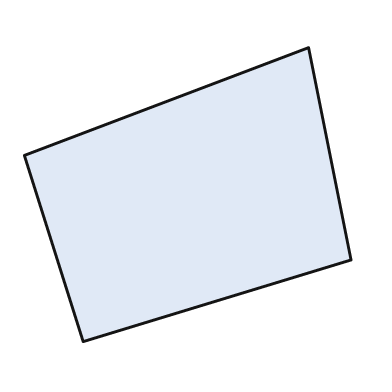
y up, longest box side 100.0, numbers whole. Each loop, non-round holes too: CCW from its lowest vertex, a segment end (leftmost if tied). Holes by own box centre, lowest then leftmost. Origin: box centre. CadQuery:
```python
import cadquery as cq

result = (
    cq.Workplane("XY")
    .moveTo(-32.0, -45.0)
    .lineTo(50.0, -20.0)
    .lineTo(37.0, 45.0)
    .lineTo(-50.0, 12.0)
    .close()
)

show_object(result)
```